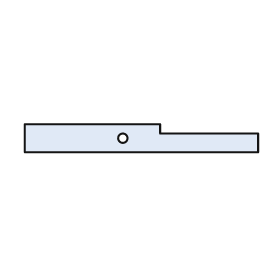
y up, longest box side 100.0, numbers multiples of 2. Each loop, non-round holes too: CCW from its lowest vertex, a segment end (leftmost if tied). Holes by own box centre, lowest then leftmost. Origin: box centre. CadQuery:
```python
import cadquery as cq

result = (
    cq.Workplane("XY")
    .moveTo(-50.0, -6.0)
    .lineTo(50.0, -6.0)
    .lineTo(50.0, 2.0)
    .lineTo(8.0, 2.0)
    .lineTo(8.0, 6.0)
    .lineTo(-50.0, 6.0)
    .close()
    .moveTo(-8.0, 0.0)
    .circle(2.0)
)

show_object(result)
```